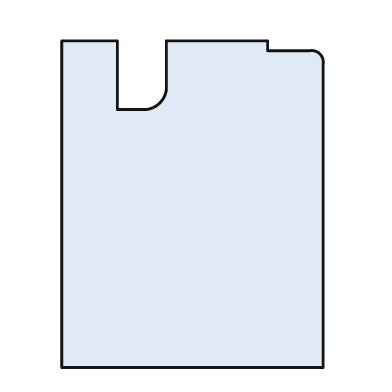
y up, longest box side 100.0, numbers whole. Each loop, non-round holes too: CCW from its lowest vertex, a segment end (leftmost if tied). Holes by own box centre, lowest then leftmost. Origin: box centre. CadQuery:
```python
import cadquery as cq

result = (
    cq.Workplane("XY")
    .moveTo(-40.0, -50.0)
    .lineTo(40.0, -50.0)
    .lineTo(40.0, 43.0)
    .threePointArc((39.0, 46.0), (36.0, 47.0))
    .lineTo(23.0, 47.0)
    .lineTo(23.0, 50.0)
    .lineTo(-8.0, 50.0)
    .lineTo(-8.0, 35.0)
    .threePointArc((-10.0, 31.0), (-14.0, 29.0))
    .lineTo(-23.0, 29.0)
    .lineTo(-23.0, 50.0)
    .lineTo(-40.0, 50.0)
    .close()
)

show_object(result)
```